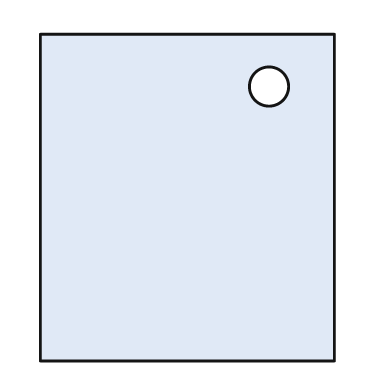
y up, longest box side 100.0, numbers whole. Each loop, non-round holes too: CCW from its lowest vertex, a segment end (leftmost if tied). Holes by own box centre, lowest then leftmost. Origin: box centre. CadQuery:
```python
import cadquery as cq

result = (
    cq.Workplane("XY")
    .moveTo(-45.0, -50.0)
    .lineTo(45.0, -50.0)
    .lineTo(45.0, 50.0)
    .lineTo(-45.0, 50.0)
    .close()
    .moveTo(25.0, 34.0)
    .circle(6.0)
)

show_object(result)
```